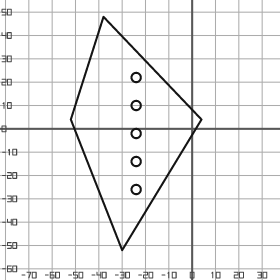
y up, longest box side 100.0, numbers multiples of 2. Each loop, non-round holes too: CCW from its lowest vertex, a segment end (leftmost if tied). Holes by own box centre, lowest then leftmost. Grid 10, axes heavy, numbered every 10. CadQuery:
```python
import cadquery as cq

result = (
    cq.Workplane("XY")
    .moveTo(-30.0, -52.0)
    .lineTo(4.0, 4.0)
    .lineTo(-38.0, 48.0)
    .lineTo(-52.0, 4.0)
    .close()
    .moveTo(-24.0, -26.0)
    .circle(2.0)
    .moveTo(-24.0, -14.0)
    .circle(2.0)
    .moveTo(-24.0, -2.0)
    .circle(2.0)
    .moveTo(-24.0, 10.0)
    .circle(2.0)
    .moveTo(-24.0, 22.0)
    .circle(2.0)
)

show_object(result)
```